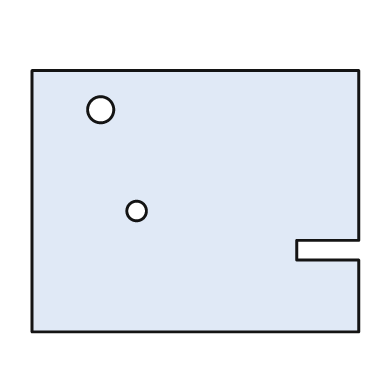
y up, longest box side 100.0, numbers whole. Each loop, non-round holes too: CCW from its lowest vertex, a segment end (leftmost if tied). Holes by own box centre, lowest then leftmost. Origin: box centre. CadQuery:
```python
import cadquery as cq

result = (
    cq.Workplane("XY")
    .moveTo(-50.0, -40.0)
    .lineTo(50.0, -40.0)
    .lineTo(50.0, -18.0)
    .lineTo(31.0, -18.0)
    .lineTo(31.0, -12.0)
    .lineTo(50.0, -12.0)
    .lineTo(50.0, 40.0)
    .lineTo(-50.0, 40.0)
    .close()
    .moveTo(-18.0, -3.0)
    .circle(3.0)
    .moveTo(-29.0, 28.0)
    .circle(4.0)
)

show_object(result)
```